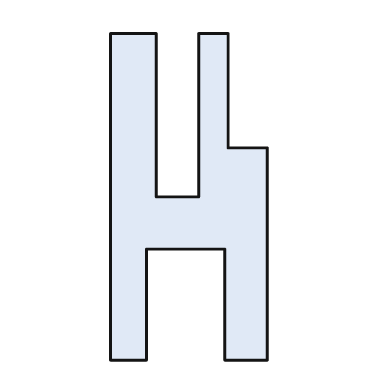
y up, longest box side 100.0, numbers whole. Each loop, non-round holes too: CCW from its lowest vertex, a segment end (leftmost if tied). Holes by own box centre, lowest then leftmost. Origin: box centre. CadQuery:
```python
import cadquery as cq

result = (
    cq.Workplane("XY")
    .moveTo(-24.0, -50.0)
    .lineTo(-13.0, -50.0)
    .lineTo(-13.0, -16.0)
    .lineTo(11.0, -16.0)
    .lineTo(11.0, -50.0)
    .lineTo(24.0, -50.0)
    .lineTo(24.0, 15.0)
    .lineTo(12.0, 15.0)
    .lineTo(12.0, 50.0)
    .lineTo(3.0, 50.0)
    .lineTo(3.0, 0.0)
    .lineTo(-10.0, 0.0)
    .lineTo(-10.0, 50.0)
    .lineTo(-24.0, 50.0)
    .close()
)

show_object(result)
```